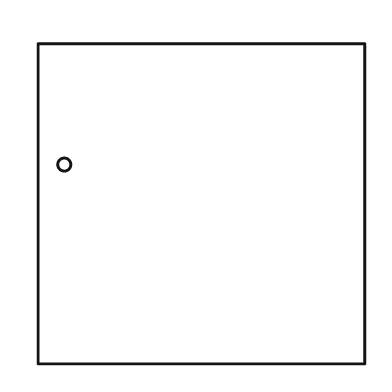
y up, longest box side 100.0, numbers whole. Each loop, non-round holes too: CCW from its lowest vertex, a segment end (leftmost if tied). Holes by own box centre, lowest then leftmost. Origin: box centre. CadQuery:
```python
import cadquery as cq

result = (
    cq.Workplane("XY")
    .moveTo(-50.0, -49.0)
    .lineTo(50.0, -49.0)
    .lineTo(50.0, 49.0)
    .lineTo(-50.0, 49.0)
    .close()
    .moveTo(-42.0, 12.0)
    .circle(2.0)
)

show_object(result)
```